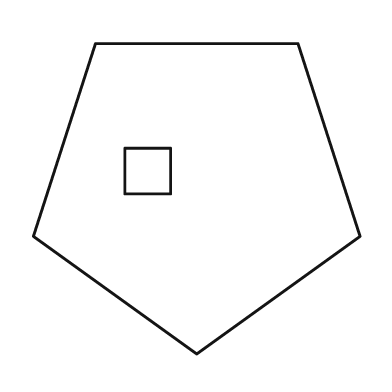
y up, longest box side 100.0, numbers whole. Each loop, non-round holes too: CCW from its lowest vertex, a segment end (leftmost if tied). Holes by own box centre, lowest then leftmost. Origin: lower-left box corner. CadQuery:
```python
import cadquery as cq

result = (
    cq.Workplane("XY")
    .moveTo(50.0, 0.0)
    .lineTo(100.0, 36.0)
    .lineTo(81.0, 95.0)
    .lineTo(19.0, 95.0)
    .lineTo(0.0, 36.0)
    .close()
    .moveTo(28.0, 49.0)
    .lineTo(42.0, 49.0)
    .lineTo(42.0, 63.0)
    .lineTo(28.0, 63.0)
    .close()
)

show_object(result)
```